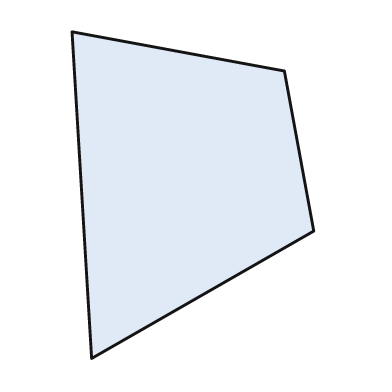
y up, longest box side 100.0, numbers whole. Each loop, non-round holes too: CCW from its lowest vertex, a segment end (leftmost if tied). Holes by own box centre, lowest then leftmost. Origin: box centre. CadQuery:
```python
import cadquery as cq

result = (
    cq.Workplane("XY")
    .moveTo(-31.0, -50.0)
    .lineTo(37.0, -11.0)
    .lineTo(28.0, 38.0)
    .lineTo(-37.0, 50.0)
    .close()
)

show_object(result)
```